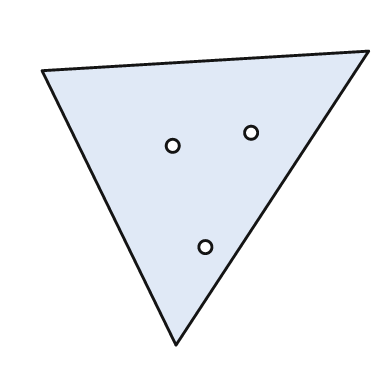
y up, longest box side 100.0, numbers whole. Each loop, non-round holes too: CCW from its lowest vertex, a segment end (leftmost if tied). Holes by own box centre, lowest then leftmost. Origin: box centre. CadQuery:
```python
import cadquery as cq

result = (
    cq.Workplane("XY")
    .moveTo(-9.0, -45.0)
    .lineTo(50.0, 45.0)
    .lineTo(-50.0, 39.0)
    .close()
    .moveTo(0.0, -15.0)
    .circle(2.0)
    .moveTo(-10.0, 16.0)
    .circle(2.0)
    .moveTo(14.0, 20.0)
    .circle(2.0)
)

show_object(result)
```